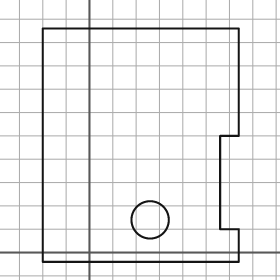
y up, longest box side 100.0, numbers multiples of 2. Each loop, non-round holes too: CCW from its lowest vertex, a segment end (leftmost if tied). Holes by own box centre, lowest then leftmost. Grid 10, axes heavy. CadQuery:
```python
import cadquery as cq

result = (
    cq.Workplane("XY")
    .moveTo(-20.0, -4.0)
    .lineTo(64.0, -4.0)
    .lineTo(64.0, 10.0)
    .lineTo(56.0, 10.0)
    .lineTo(56.0, 50.0)
    .lineTo(64.0, 50.0)
    .lineTo(64.0, 96.0)
    .lineTo(-20.0, 96.0)
    .close()
    .moveTo(26.0, 14.0)
    .circle(8.0)
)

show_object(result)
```